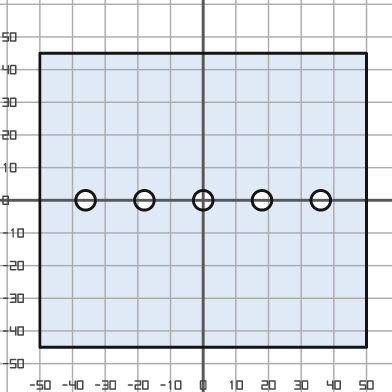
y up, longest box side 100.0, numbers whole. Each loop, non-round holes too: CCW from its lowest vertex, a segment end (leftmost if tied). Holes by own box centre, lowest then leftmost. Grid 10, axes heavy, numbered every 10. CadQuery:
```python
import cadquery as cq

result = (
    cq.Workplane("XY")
    .moveTo(-50.0, -45.0)
    .lineTo(50.0, -45.0)
    .lineTo(50.0, 45.0)
    .lineTo(-50.0, 45.0)
    .close()
    .moveTo(-36.0, 0.0)
    .circle(3.0)
    .moveTo(-18.0, 0.0)
    .circle(3.0)
    .moveTo(0.0, 0.0)
    .circle(3.0)
    .moveTo(18.0, 0.0)
    .circle(3.0)
    .moveTo(36.0, 0.0)
    .circle(3.0)
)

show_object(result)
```